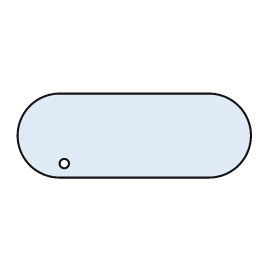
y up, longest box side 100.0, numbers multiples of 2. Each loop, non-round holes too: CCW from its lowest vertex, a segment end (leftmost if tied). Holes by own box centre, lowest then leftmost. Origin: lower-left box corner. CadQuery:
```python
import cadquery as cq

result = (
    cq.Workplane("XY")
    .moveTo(18.0, 0.0)
    .lineTo(82.0, 0.0)
    .threePointArc((100.0, 18.0), (82.0, 36.0))
    .lineTo(18.0, 36.0)
    .threePointArc((0.0, 18.0), (18.0, 0.0))
    .close()
    .moveTo(20.0, 6.0)
    .circle(2.0)
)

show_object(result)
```